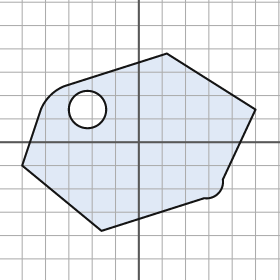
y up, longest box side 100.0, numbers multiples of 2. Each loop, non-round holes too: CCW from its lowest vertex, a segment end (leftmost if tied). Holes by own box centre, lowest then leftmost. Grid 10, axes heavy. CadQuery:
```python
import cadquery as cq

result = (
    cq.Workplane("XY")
    .moveTo(-16.0, -38.0)
    .lineTo(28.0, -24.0)
    .threePointArc((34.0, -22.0), (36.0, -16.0))
    .lineTo(50.0, 14.0)
    .lineTo(12.0, 38.0)
    .lineTo(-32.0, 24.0)
    .threePointArc((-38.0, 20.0), (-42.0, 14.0))
    .lineTo(-50.0, -10.0)
    .close()
    .moveTo(-22.0, 14.0)
    .circle(8.0)
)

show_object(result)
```